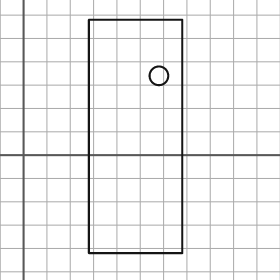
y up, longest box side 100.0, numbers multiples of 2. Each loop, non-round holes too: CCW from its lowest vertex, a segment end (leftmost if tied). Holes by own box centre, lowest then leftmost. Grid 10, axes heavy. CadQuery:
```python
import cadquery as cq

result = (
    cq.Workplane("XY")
    .moveTo(28.0, -42.0)
    .lineTo(68.0, -42.0)
    .lineTo(68.0, 58.0)
    .lineTo(28.0, 58.0)
    .close()
    .moveTo(58.0, 34.0)
    .circle(4.0)
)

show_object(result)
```